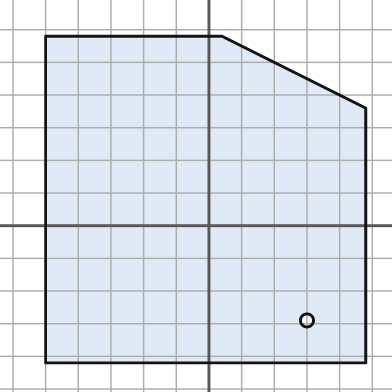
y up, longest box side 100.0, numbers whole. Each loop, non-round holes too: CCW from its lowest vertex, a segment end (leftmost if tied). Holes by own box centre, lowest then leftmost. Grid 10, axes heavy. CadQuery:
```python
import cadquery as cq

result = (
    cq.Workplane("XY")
    .moveTo(-50.0, -42.0)
    .lineTo(48.0, -42.0)
    .lineTo(48.0, 36.0)
    .lineTo(4.0, 58.0)
    .lineTo(-50.0, 58.0)
    .close()
    .moveTo(30.0, -29.0)
    .circle(2.0)
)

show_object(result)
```